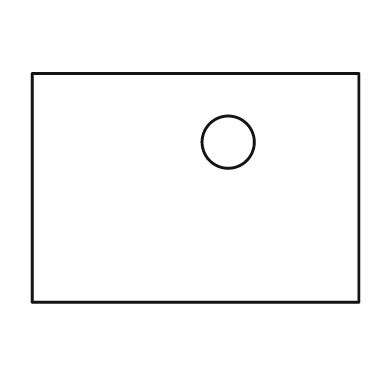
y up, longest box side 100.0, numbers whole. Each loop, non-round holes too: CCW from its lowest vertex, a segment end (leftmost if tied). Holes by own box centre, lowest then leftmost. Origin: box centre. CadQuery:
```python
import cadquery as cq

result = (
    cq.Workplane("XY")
    .moveTo(-50.0, -35.0)
    .lineTo(50.0, -35.0)
    .lineTo(50.0, 35.0)
    .lineTo(-50.0, 35.0)
    .close()
    .moveTo(10.0, 14.0)
    .circle(8.0)
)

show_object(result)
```